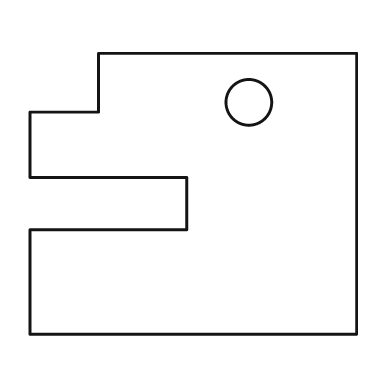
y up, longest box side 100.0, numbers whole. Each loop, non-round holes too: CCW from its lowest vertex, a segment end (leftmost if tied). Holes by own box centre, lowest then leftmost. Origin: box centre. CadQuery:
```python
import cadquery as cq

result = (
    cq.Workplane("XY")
    .moveTo(-50.0, -43.0)
    .lineTo(50.0, -43.0)
    .lineTo(50.0, 43.0)
    .lineTo(-29.0, 43.0)
    .lineTo(-29.0, 25.0)
    .lineTo(-50.0, 25.0)
    .lineTo(-50.0, 5.0)
    .lineTo(-2.0, 5.0)
    .lineTo(-2.0, -11.0)
    .lineTo(-50.0, -11.0)
    .close()
    .moveTo(17.0, 28.0)
    .circle(7.0)
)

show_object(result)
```